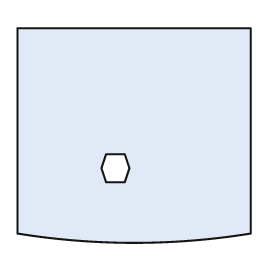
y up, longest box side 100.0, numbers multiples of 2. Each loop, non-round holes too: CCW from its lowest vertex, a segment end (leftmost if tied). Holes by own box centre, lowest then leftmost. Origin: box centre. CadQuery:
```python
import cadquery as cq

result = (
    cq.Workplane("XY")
    .moveTo(-50.0, -42.0)
    .threePointArc((0.0, -46.0), (50.0, -42.0))
    .lineTo(50.0, 46.0)
    .lineTo(-50.0, 46.0)
    .close()
    .moveTo(-12.0, -20.0)
    .lineTo(-4.0, -20.0)
    .lineTo(-2.0, -14.0)
    .lineTo(-4.0, -8.0)
    .lineTo(-12.0, -8.0)
    .lineTo(-14.0, -14.0)
    .close()
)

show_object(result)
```